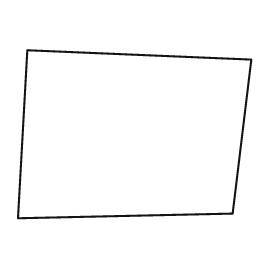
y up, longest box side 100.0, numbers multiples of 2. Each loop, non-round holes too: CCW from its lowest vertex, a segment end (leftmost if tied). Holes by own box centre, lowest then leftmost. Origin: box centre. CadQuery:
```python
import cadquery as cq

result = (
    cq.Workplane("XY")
    .moveTo(-50.0, -36.0)
    .lineTo(42.0, -34.0)
    .lineTo(50.0, 32.0)
    .lineTo(-46.0, 36.0)
    .close()
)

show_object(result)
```